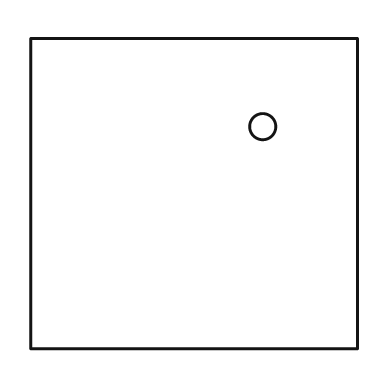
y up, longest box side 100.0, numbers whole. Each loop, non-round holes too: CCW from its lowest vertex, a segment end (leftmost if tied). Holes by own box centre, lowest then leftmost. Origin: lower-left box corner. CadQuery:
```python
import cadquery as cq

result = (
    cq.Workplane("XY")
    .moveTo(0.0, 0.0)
    .lineTo(100.0, 0.0)
    .lineTo(100.0, 95.0)
    .lineTo(0.0, 95.0)
    .close()
    .moveTo(71.0, 68.0)
    .circle(4.0)
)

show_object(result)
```